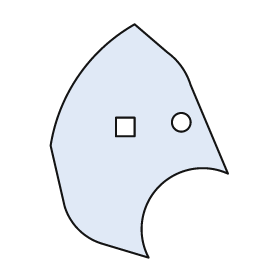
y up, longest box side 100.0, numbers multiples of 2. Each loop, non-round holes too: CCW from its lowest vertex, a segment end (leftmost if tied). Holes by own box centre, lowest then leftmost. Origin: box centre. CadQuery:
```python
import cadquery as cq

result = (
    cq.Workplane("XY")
    .moveTo(4.0, -50.0)
    .threePointArc((8.0, -20.0), (38.0, -14.0))
    .lineTo(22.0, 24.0)
    .threePointArc((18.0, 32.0), (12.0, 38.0))
    .lineTo(-2.0, 50.0)
    .threePointArc((-26.0, 28.0), (-38.0, -2.0))
    .lineTo(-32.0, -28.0)
    .threePointArc((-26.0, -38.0), (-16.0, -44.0))
    .close()
    .moveTo(-10.0, 2.0)
    .lineTo(-2.0, 2.0)
    .lineTo(-2.0, 10.0)
    .lineTo(-10.0, 10.0)
    .close()
    .moveTo(18.0, 8.0)
    .circle(4.0)
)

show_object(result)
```